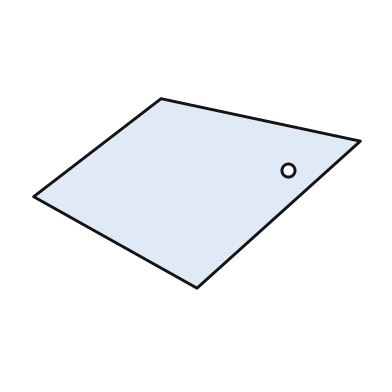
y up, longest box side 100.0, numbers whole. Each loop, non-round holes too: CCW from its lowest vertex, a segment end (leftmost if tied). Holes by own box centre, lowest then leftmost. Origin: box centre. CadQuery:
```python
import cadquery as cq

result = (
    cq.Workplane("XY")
    .moveTo(0.0, -29.0)
    .lineTo(50.0, 16.0)
    .lineTo(-11.0, 29.0)
    .lineTo(-50.0, -1.0)
    .close()
    .moveTo(28.0, 7.0)
    .circle(2.0)
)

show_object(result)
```